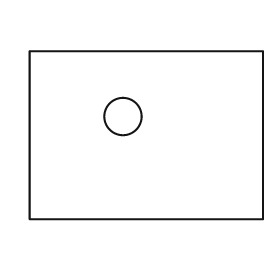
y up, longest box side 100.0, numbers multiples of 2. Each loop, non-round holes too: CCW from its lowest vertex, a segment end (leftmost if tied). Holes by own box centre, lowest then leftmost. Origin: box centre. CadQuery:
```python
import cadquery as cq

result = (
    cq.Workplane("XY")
    .moveTo(-50.0, -36.0)
    .lineTo(50.0, -36.0)
    .lineTo(50.0, 36.0)
    .lineTo(-50.0, 36.0)
    .close()
    .moveTo(-10.0, 8.0)
    .circle(8.0)
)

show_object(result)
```